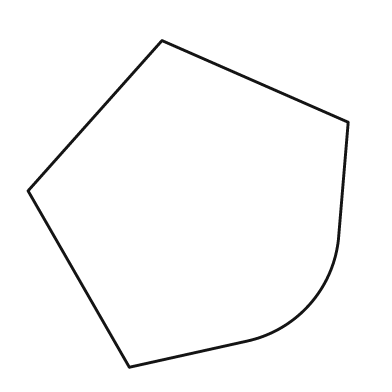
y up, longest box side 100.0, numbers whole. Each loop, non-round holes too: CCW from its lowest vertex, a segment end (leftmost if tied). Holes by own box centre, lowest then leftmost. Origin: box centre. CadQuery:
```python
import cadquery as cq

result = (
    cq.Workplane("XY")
    .moveTo(-18.0, -50.0)
    .lineTo(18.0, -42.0)
    .threePointArc((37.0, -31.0), (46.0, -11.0))
    .lineTo(49.0, 25.0)
    .lineTo(-8.0, 50.0)
    .lineTo(-49.0, 4.0)
    .close()
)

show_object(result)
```